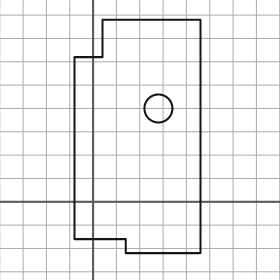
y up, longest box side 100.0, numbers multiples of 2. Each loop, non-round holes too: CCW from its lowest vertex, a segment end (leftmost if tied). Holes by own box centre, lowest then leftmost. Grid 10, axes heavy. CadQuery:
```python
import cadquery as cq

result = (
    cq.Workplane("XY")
    .moveTo(14.0, -22.0)
    .lineTo(46.0, -22.0)
    .lineTo(46.0, 78.0)
    .lineTo(4.0, 78.0)
    .lineTo(4.0, 62.0)
    .lineTo(-8.0, 62.0)
    .lineTo(-8.0, -16.0)
    .lineTo(14.0, -16.0)
    .close()
    .moveTo(28.0, 40.0)
    .circle(6.0)
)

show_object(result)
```